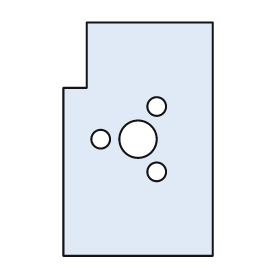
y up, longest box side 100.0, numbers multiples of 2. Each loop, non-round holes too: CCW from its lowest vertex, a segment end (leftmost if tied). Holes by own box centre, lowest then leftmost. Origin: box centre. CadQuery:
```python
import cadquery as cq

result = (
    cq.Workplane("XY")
    .moveTo(-32.0, -50.0)
    .lineTo(32.0, -50.0)
    .lineTo(32.0, 50.0)
    .lineTo(-22.0, 50.0)
    .lineTo(-22.0, 22.0)
    .lineTo(-32.0, 22.0)
    .close()
    .moveTo(8.0, -14.0)
    .circle(4.0)
    .moveTo(-16.0, 0.0)
    .circle(4.0)
    .moveTo(0.0, 0.0)
    .circle(8.0)
    .moveTo(8.0, 14.0)
    .circle(4.0)
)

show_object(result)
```